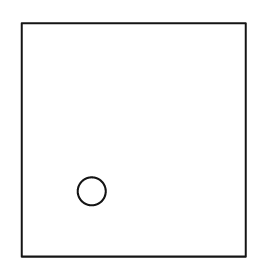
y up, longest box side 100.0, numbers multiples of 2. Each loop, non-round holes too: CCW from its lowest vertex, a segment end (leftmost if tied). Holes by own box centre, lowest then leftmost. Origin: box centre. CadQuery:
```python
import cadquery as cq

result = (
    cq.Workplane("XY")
    .moveTo(-48.0, -50.0)
    .lineTo(48.0, -50.0)
    .lineTo(48.0, 50.0)
    .lineTo(-48.0, 50.0)
    .close()
    .moveTo(-18.0, -22.0)
    .circle(6.0)
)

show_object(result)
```